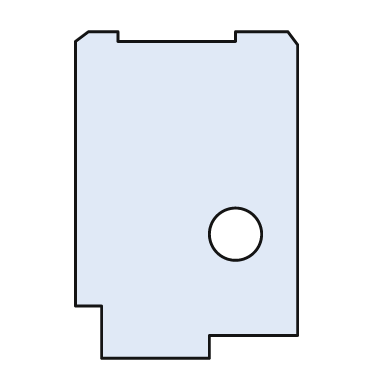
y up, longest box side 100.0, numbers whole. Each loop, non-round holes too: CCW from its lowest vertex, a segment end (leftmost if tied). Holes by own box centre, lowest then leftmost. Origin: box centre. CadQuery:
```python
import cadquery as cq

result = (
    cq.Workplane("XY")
    .moveTo(-26.0, -50.0)
    .lineTo(7.0, -50.0)
    .lineTo(7.0, -43.0)
    .lineTo(34.0, -43.0)
    .lineTo(34.0, 46.0)
    .lineTo(31.0, 50.0)
    .lineTo(15.0, 50.0)
    .lineTo(15.0, 47.0)
    .lineTo(-21.0, 47.0)
    .lineTo(-21.0, 50.0)
    .lineTo(-30.0, 50.0)
    .lineTo(-34.0, 47.0)
    .lineTo(-34.0, -34.0)
    .lineTo(-26.0, -34.0)
    .close()
    .moveTo(15.0, -12.0)
    .circle(8.0)
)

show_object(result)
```